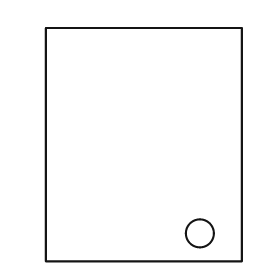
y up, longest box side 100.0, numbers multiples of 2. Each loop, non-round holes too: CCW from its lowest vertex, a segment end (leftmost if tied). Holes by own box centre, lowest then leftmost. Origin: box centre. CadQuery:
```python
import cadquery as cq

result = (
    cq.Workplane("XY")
    .moveTo(-42.0, -50.0)
    .lineTo(42.0, -50.0)
    .lineTo(42.0, 50.0)
    .lineTo(-42.0, 50.0)
    .close()
    .moveTo(24.0, -38.0)
    .circle(6.0)
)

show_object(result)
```